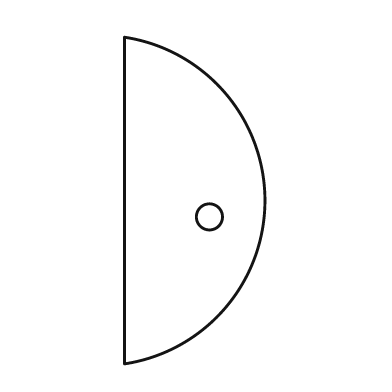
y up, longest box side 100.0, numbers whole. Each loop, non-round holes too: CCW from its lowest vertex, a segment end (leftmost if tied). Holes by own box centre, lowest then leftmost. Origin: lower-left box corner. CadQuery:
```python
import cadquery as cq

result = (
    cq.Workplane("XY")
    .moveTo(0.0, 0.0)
    .threePointArc((43.0, 50.0), (0.0, 100.0))
    .close()
    .moveTo(26.0, 45.0)
    .circle(4.0)
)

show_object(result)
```